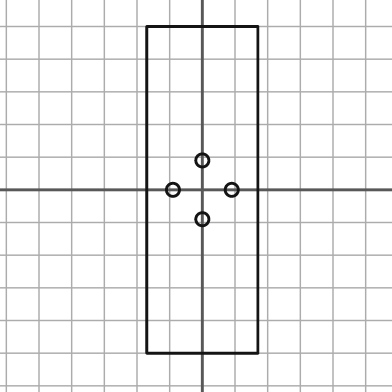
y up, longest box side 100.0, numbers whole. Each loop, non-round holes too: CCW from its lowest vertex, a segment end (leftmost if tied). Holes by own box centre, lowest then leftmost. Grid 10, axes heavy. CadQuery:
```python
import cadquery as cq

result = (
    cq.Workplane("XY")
    .moveTo(-17.0, -50.0)
    .lineTo(17.0, -50.0)
    .lineTo(17.0, 50.0)
    .lineTo(-17.0, 50.0)
    .close()
    .moveTo(0.0, -9.0)
    .circle(2.0)
    .moveTo(-9.0, 0.0)
    .circle(2.0)
    .moveTo(9.0, 0.0)
    .circle(2.0)
    .moveTo(0.0, 9.0)
    .circle(2.0)
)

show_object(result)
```